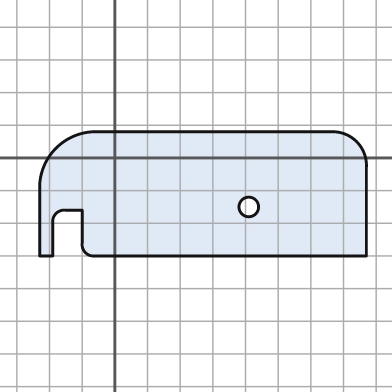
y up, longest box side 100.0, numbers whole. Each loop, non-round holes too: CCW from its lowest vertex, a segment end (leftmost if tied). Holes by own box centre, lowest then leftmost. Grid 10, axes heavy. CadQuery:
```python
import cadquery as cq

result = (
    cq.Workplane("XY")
    .moveTo(-23.0, -30.0)
    .lineTo(-19.0, -30.0)
    .lineTo(-19.0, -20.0)
    .threePointArc((-18.0, -17.0), (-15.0, -16.0))
    .lineTo(-10.0, -16.0)
    .lineTo(-10.0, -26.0)
    .threePointArc((-9.0, -29.0), (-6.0, -30.0))
    .lineTo(77.0, -30.0)
    .lineTo(77.0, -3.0)
    .threePointArc((74.0, 5.0), (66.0, 8.0))
    .lineTo(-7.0, 8.0)
    .threePointArc((-18.0, 3.0), (-23.0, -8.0))
    .close()
    .moveTo(41.0, -15.0)
    .circle(3.0)
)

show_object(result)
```